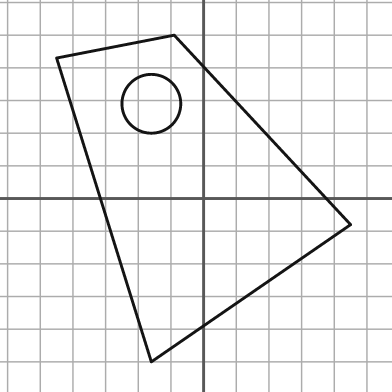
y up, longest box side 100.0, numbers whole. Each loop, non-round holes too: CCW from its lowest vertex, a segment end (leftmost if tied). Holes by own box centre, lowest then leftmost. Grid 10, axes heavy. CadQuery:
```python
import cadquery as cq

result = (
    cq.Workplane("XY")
    .moveTo(-16.0, -50.0)
    .lineTo(45.0, -8.0)
    .lineTo(-9.0, 50.0)
    .lineTo(-45.0, 43.0)
    .close()
    .moveTo(-16.0, 29.0)
    .circle(9.0)
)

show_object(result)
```